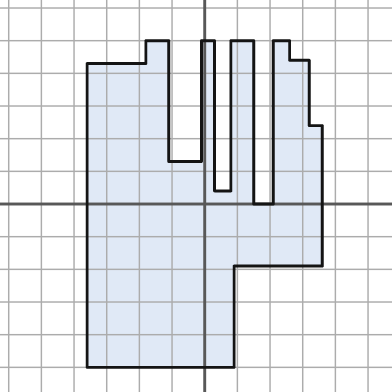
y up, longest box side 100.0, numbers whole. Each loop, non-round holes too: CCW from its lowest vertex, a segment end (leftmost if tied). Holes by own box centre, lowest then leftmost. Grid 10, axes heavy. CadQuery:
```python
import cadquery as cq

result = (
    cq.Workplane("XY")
    .moveTo(-36.0, -50.0)
    .lineTo(9.0, -50.0)
    .lineTo(9.0, -19.0)
    .lineTo(36.0, -19.0)
    .lineTo(36.0, 24.0)
    .lineTo(32.0, 24.0)
    .lineTo(32.0, 44.0)
    .lineTo(26.0, 44.0)
    .lineTo(26.0, 50.0)
    .lineTo(21.0, 50.0)
    .lineTo(21.0, 0.0)
    .lineTo(15.0, 0.0)
    .lineTo(15.0, 50.0)
    .lineTo(8.0, 50.0)
    .lineTo(8.0, 4.0)
    .lineTo(3.0, 4.0)
    .lineTo(3.0, 50.0)
    .lineTo(-1.0, 50.0)
    .lineTo(-1.0, 13.0)
    .lineTo(-11.0, 13.0)
    .lineTo(-11.0, 50.0)
    .lineTo(-18.0, 50.0)
    .lineTo(-18.0, 43.0)
    .lineTo(-36.0, 43.0)
    .close()
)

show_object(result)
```